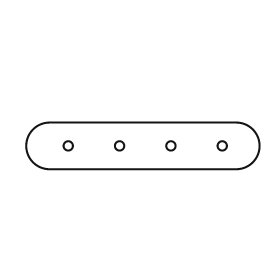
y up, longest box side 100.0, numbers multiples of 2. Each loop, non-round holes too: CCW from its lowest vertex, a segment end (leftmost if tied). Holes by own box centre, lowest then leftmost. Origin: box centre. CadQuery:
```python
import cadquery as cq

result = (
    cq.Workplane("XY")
    .moveTo(-40.0, -10.0)
    .lineTo(40.0, -10.0)
    .threePointArc((50.0, 0.0), (40.0, 10.0))
    .lineTo(-40.0, 10.0)
    .threePointArc((-50.0, 0.0), (-40.0, -10.0))
    .close()
    .moveTo(-32.0, 0.0)
    .circle(2.0)
    .moveTo(-10.0, 0.0)
    .circle(2.0)
    .moveTo(12.0, 0.0)
    .circle(2.0)
    .moveTo(34.0, 0.0)
    .circle(2.0)
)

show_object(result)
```